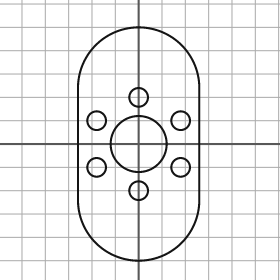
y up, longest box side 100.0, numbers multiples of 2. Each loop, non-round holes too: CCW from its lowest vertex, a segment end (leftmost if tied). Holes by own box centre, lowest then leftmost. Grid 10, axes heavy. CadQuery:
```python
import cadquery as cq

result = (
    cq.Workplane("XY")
    .moveTo(-26.0, -24.0)
    .threePointArc((0.0, -50.0), (26.0, -24.0))
    .lineTo(26.0, 24.0)
    .threePointArc((0.0, 50.0), (-26.0, 24.0))
    .close()
    .moveTo(0.0, -20.0)
    .circle(4.0)
    .moveTo(-18.0, -10.0)
    .circle(4.0)
    .moveTo(18.0, -10.0)
    .circle(4.0)
    .moveTo(0.0, 0.0)
    .circle(12.0)
    .moveTo(-18.0, 10.0)
    .circle(4.0)
    .moveTo(18.0, 10.0)
    .circle(4.0)
    .moveTo(0.0, 20.0)
    .circle(4.0)
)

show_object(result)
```